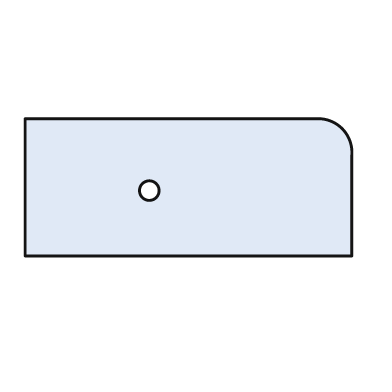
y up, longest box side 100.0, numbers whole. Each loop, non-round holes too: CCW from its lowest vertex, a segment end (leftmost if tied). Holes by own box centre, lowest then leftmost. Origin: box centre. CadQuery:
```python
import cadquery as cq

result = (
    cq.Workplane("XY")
    .moveTo(-50.0, -21.0)
    .lineTo(50.0, -21.0)
    .lineTo(50.0, 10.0)
    .threePointArc((47.0, 18.0), (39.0, 21.0))
    .lineTo(-50.0, 21.0)
    .close()
    .moveTo(-12.0, -1.0)
    .circle(3.0)
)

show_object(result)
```